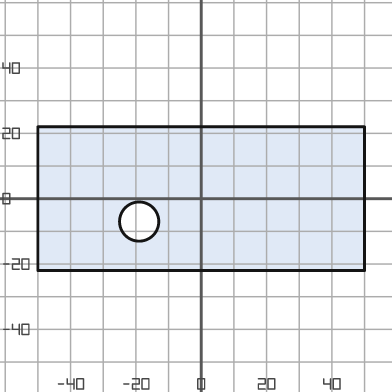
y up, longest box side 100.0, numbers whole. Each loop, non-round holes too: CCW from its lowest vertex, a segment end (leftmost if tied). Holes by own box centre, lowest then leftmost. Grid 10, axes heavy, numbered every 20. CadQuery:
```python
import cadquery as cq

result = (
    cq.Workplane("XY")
    .moveTo(-50.0, -22.0)
    .lineTo(50.0, -22.0)
    .lineTo(50.0, 22.0)
    .lineTo(-50.0, 22.0)
    .close()
    .moveTo(-19.0, -7.0)
    .circle(6.0)
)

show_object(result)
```